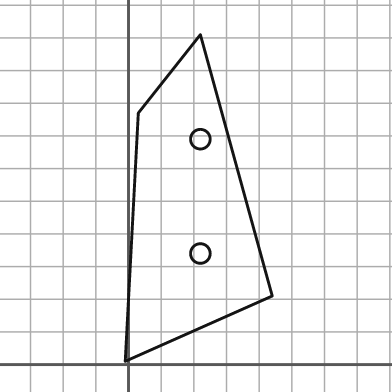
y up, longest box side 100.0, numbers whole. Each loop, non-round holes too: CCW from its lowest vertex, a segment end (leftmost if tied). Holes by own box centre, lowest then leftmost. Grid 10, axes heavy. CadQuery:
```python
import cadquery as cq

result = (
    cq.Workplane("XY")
    .moveTo(-1.0, 1.0)
    .lineTo(44.0, 21.0)
    .lineTo(22.0, 101.0)
    .lineTo(3.0, 77.0)
    .close()
    .moveTo(22.0, 34.0)
    .circle(3.0)
    .moveTo(22.0, 69.0)
    .circle(3.0)
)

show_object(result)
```